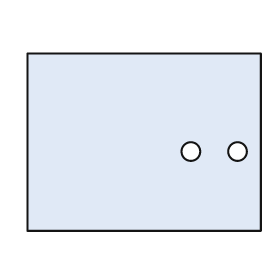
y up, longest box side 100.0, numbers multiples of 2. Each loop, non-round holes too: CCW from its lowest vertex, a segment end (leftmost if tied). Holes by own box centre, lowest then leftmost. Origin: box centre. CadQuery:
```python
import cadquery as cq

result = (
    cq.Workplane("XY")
    .moveTo(-50.0, -38.0)
    .lineTo(50.0, -38.0)
    .lineTo(50.0, 38.0)
    .lineTo(-50.0, 38.0)
    .close()
    .moveTo(20.0, -4.0)
    .circle(4.0)
    .moveTo(40.0, -4.0)
    .circle(4.0)
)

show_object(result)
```